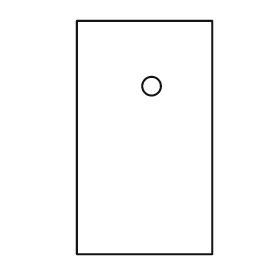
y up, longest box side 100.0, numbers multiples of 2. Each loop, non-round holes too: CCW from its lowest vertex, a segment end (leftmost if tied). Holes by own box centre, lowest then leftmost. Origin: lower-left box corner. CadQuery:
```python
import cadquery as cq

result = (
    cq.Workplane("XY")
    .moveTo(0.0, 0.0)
    .lineTo(58.0, 0.0)
    .lineTo(58.0, 100.0)
    .lineTo(0.0, 100.0)
    .close()
    .moveTo(32.0, 72.0)
    .circle(4.0)
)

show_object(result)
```